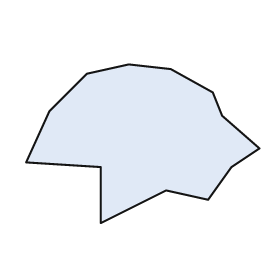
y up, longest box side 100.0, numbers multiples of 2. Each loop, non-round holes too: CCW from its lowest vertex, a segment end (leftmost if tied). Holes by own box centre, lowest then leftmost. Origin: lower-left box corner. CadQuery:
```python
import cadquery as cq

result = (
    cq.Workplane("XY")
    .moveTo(32.0, 0.0)
    .lineTo(60.0, 14.0)
    .lineTo(78.0, 10.0)
    .lineTo(88.0, 24.0)
    .lineTo(100.0, 32.0)
    .lineTo(84.0, 46.0)
    .lineTo(80.0, 56.0)
    .lineTo(62.0, 66.0)
    .lineTo(44.0, 68.0)
    .lineTo(26.0, 64.0)
    .lineTo(10.0, 48.0)
    .lineTo(0.0, 26.0)
    .lineTo(32.0, 24.0)
    .close()
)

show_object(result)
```